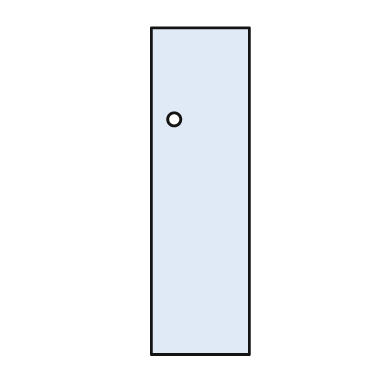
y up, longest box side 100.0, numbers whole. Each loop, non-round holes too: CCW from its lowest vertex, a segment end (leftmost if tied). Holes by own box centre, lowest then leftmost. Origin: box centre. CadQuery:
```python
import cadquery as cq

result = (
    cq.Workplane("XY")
    .moveTo(-15.0, -50.0)
    .lineTo(15.0, -50.0)
    .lineTo(15.0, 50.0)
    .lineTo(-15.0, 50.0)
    .close()
    .moveTo(-8.0, 22.0)
    .circle(2.0)
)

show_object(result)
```